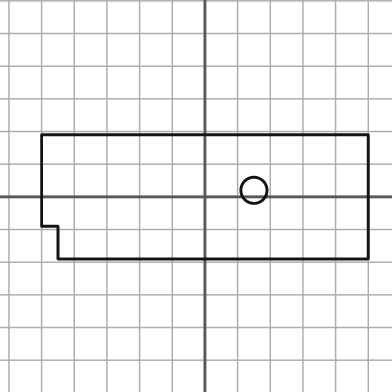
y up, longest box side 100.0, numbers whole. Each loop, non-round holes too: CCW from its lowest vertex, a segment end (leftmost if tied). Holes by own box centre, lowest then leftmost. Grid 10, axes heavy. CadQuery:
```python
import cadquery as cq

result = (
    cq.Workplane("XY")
    .moveTo(-45.0, -19.0)
    .lineTo(50.0, -19.0)
    .lineTo(50.0, 19.0)
    .lineTo(-50.0, 19.0)
    .lineTo(-50.0, -9.0)
    .lineTo(-45.0, -9.0)
    .close()
    .moveTo(15.0, 2.0)
    .circle(4.0)
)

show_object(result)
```